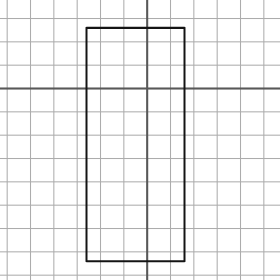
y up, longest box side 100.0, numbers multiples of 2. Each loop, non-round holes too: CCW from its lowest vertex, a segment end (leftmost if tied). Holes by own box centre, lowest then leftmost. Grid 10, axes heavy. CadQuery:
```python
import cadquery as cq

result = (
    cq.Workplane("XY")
    .moveTo(-26.0, -74.0)
    .lineTo(16.0, -74.0)
    .lineTo(16.0, 26.0)
    .lineTo(-26.0, 26.0)
    .close()
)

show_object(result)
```